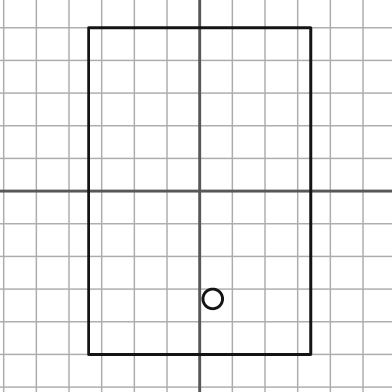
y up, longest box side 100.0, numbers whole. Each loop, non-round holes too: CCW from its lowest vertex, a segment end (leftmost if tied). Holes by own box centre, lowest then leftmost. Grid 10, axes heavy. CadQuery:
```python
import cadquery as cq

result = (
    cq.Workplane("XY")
    .moveTo(-34.0, -50.0)
    .lineTo(34.0, -50.0)
    .lineTo(34.0, 50.0)
    .lineTo(-34.0, 50.0)
    .close()
    .moveTo(4.0, -33.0)
    .circle(3.0)
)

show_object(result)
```